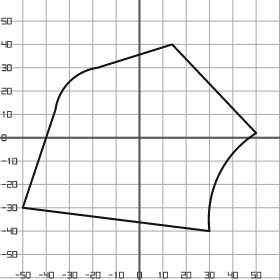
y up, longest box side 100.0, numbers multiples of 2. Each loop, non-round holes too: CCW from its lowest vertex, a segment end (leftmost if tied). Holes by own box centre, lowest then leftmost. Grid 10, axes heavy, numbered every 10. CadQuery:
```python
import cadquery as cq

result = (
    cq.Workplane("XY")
    .moveTo(30.0, -40.0)
    .threePointArc((34.0, -16.0), (50.0, 2.0))
    .lineTo(14.0, 40.0)
    .lineTo(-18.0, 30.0)
    .threePointArc((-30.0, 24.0), (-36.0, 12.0))
    .lineTo(-50.0, -30.0)
    .close()
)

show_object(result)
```